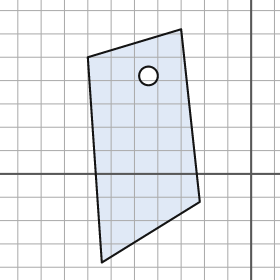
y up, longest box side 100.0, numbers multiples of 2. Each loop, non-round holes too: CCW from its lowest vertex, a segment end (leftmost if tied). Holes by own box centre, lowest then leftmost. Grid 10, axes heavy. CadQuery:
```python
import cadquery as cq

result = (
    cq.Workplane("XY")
    .moveTo(-64.0, -38.0)
    .lineTo(-22.0, -12.0)
    .lineTo(-30.0, 62.0)
    .lineTo(-70.0, 50.0)
    .close()
    .moveTo(-44.0, 42.0)
    .circle(4.0)
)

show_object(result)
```